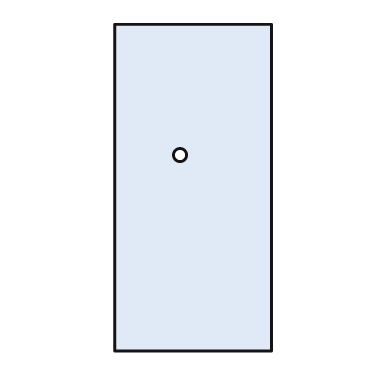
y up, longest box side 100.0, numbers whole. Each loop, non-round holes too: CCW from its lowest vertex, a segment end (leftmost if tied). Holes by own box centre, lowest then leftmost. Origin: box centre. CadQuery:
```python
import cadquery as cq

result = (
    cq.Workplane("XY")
    .moveTo(-24.0, -50.0)
    .lineTo(24.0, -50.0)
    .lineTo(24.0, 50.0)
    .lineTo(-24.0, 50.0)
    .close()
    .moveTo(-4.0, 10.0)
    .circle(2.0)
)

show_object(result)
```